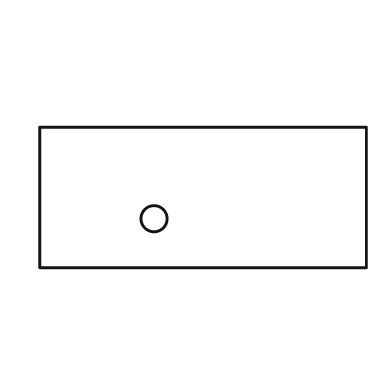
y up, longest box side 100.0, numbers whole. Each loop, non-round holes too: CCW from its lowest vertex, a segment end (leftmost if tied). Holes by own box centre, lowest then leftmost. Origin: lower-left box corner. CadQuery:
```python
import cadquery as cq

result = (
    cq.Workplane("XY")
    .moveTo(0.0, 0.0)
    .lineTo(100.0, 0.0)
    .lineTo(100.0, 43.0)
    .lineTo(0.0, 43.0)
    .close()
    .moveTo(35.0, 15.0)
    .circle(4.0)
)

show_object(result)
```